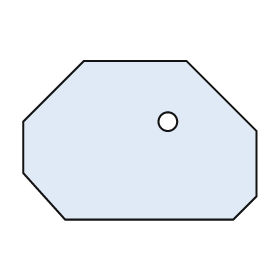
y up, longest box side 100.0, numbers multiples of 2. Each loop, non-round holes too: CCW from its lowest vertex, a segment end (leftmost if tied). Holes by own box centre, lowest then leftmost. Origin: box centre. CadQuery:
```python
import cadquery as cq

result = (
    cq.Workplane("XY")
    .moveTo(-32.0, -34.0)
    .lineTo(40.0, -34.0)
    .lineTo(50.0, -24.0)
    .lineTo(50.0, 4.0)
    .lineTo(20.0, 34.0)
    .lineTo(-24.0, 34.0)
    .lineTo(-50.0, 8.0)
    .lineTo(-50.0, -14.0)
    .close()
    .moveTo(12.0, 8.0)
    .circle(4.0)
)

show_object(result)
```